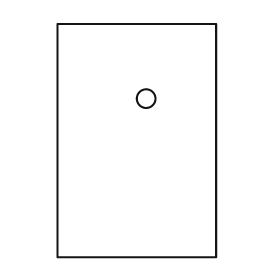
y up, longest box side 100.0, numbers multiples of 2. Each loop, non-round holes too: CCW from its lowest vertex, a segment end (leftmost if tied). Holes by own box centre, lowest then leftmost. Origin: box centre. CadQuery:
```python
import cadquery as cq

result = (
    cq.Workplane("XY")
    .moveTo(-34.0, -50.0)
    .lineTo(34.0, -50.0)
    .lineTo(34.0, 50.0)
    .lineTo(-34.0, 50.0)
    .close()
    .moveTo(4.0, 18.0)
    .circle(4.0)
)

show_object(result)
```